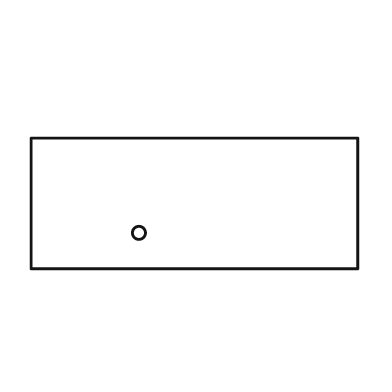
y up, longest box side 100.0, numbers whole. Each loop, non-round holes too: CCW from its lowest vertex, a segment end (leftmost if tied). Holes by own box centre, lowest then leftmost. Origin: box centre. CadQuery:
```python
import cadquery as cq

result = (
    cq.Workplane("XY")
    .moveTo(-50.0, -20.0)
    .lineTo(50.0, -20.0)
    .lineTo(50.0, 20.0)
    .lineTo(-50.0, 20.0)
    .close()
    .moveTo(-17.0, -9.0)
    .circle(2.0)
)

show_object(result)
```